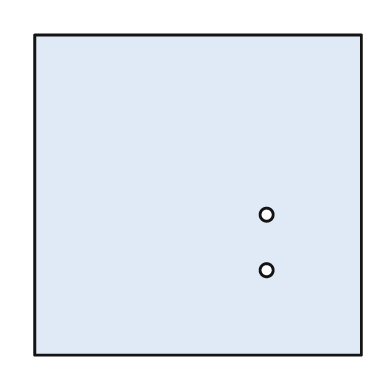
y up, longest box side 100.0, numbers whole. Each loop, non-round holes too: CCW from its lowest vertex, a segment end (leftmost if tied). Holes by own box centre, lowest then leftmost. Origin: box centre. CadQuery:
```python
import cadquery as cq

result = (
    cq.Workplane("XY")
    .moveTo(-50.0, -49.0)
    .lineTo(50.0, -49.0)
    .lineTo(50.0, 49.0)
    .lineTo(-50.0, 49.0)
    .close()
    .moveTo(21.0, -23.0)
    .circle(2.0)
    .moveTo(21.0, -6.0)
    .circle(2.0)
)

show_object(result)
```